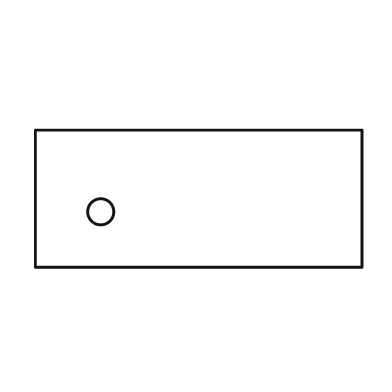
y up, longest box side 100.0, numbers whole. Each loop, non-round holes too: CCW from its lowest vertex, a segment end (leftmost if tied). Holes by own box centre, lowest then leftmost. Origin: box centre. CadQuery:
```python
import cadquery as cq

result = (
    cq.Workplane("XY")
    .moveTo(-50.0, -21.0)
    .lineTo(50.0, -21.0)
    .lineTo(50.0, 21.0)
    .lineTo(-50.0, 21.0)
    .close()
    .moveTo(-30.0, -4.0)
    .circle(4.0)
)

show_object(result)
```